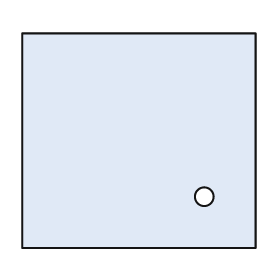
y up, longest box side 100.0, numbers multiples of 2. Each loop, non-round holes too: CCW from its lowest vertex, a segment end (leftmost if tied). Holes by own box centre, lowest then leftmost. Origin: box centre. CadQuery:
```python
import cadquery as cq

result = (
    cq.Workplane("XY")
    .moveTo(-50.0, -46.0)
    .lineTo(50.0, -46.0)
    .lineTo(50.0, 46.0)
    .lineTo(-50.0, 46.0)
    .close()
    .moveTo(28.0, -24.0)
    .circle(4.0)
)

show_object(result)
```